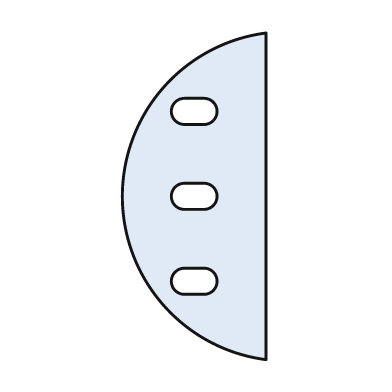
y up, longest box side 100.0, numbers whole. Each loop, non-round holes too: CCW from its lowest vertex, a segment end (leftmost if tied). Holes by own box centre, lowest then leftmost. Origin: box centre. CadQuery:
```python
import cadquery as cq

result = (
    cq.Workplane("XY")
    .moveTo(22.0, -50.0)
    .lineTo(22.0, 50.0)
    .threePointArc((-22.0, 0.0), (22.0, -50.0))
    .close()
    .moveTo(-3.0, -30.0)
    .lineTo(3.0, -30.0)
    .threePointArc((7.0, -26.0), (3.0, -22.0))
    .lineTo(-3.0, -22.0)
    .threePointArc((-7.0, -26.0), (-3.0, -30.0))
    .close()
    .moveTo(-3.0, -4.0)
    .lineTo(3.0, -4.0)
    .threePointArc((7.0, 0.0), (3.0, 4.0))
    .lineTo(-3.0, 4.0)
    .threePointArc((-7.0, 0.0), (-3.0, -4.0))
    .close()
    .moveTo(-3.0, 22.0)
    .lineTo(3.0, 22.0)
    .threePointArc((7.0, 26.0), (3.0, 30.0))
    .lineTo(-3.0, 30.0)
    .threePointArc((-7.0, 26.0), (-3.0, 22.0))
    .close()
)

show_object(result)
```